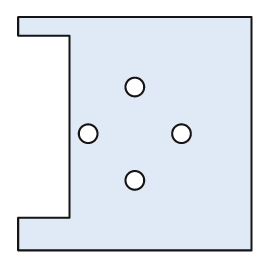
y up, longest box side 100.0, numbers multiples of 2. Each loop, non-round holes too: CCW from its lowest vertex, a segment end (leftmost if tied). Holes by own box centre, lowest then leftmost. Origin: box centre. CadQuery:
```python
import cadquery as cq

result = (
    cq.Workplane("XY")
    .moveTo(-50.0, -50.0)
    .lineTo(50.0, -50.0)
    .lineTo(50.0, 50.0)
    .lineTo(-50.0, 50.0)
    .lineTo(-50.0, 42.0)
    .lineTo(-28.0, 42.0)
    .lineTo(-28.0, -36.0)
    .lineTo(-50.0, -36.0)
    .close()
    .moveTo(0.0, -20.0)
    .circle(4.0)
    .moveTo(-20.0, 0.0)
    .circle(4.0)
    .moveTo(20.0, 0.0)
    .circle(4.0)
    .moveTo(0.0, 20.0)
    .circle(4.0)
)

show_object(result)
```